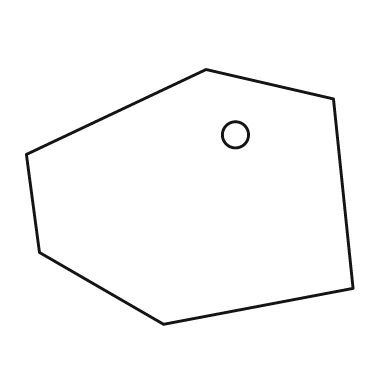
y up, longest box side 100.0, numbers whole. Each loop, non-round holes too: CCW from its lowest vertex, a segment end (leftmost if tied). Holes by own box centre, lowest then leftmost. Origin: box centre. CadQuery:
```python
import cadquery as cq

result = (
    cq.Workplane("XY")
    .moveTo(-8.0, -39.0)
    .lineTo(50.0, -28.0)
    .lineTo(44.0, 30.0)
    .lineTo(5.0, 39.0)
    .lineTo(-50.0, 13.0)
    .lineTo(-46.0, -17.0)
    .close()
    .moveTo(14.0, 19.0)
    .circle(4.0)
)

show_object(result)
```